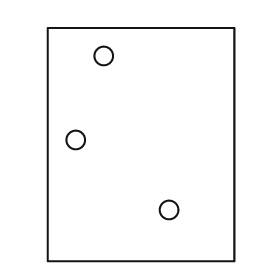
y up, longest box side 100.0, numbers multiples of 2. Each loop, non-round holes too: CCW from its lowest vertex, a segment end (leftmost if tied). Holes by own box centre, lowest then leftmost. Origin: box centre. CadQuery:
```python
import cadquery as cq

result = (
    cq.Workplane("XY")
    .moveTo(-40.0, -50.0)
    .lineTo(40.0, -50.0)
    .lineTo(40.0, 50.0)
    .lineTo(-40.0, 50.0)
    .close()
    .moveTo(12.0, -28.0)
    .circle(4.0)
    .moveTo(-28.0, 2.0)
    .circle(4.0)
    .moveTo(-16.0, 38.0)
    .circle(4.0)
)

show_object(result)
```